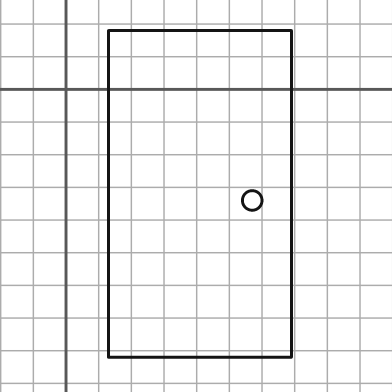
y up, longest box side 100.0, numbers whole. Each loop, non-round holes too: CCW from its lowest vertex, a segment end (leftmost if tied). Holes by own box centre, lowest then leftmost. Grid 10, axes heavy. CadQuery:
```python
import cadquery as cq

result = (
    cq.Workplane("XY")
    .moveTo(13.0, -82.0)
    .lineTo(69.0, -82.0)
    .lineTo(69.0, 18.0)
    .lineTo(13.0, 18.0)
    .close()
    .moveTo(57.0, -34.0)
    .circle(3.0)
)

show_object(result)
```